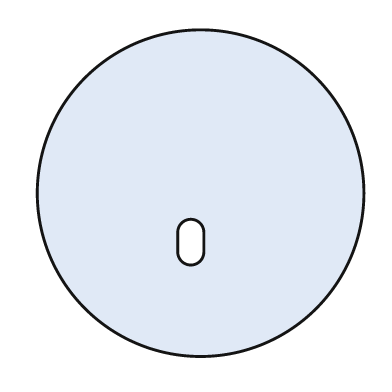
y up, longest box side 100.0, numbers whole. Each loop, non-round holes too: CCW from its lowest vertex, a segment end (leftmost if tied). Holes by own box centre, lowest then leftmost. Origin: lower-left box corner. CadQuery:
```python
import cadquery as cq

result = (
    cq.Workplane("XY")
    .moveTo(50.0, 50.0)
    .circle(50.0)
    .moveTo(43.0, 32.0)
    .threePointArc((47.0, 28.0), (51.0, 32.0))
    .lineTo(51.0, 38.0)
    .threePointArc((47.0, 42.0), (43.0, 38.0))
    .close()
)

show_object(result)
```